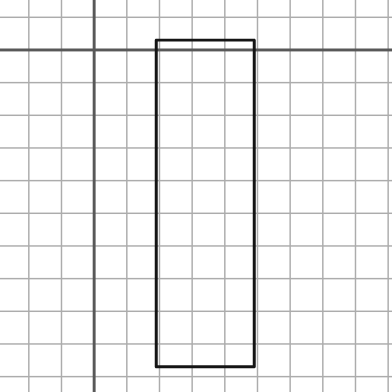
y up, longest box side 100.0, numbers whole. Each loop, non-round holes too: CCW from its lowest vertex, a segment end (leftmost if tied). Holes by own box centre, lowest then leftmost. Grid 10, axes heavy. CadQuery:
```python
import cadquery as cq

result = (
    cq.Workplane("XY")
    .moveTo(19.0, -97.0)
    .lineTo(49.0, -97.0)
    .lineTo(49.0, 3.0)
    .lineTo(19.0, 3.0)
    .close()
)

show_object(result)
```